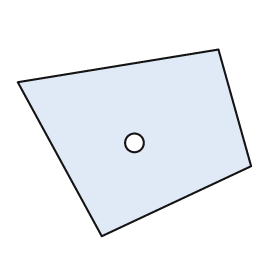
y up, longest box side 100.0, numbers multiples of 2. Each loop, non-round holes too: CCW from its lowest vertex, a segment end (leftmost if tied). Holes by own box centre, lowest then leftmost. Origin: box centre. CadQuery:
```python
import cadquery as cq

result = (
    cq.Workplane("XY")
    .moveTo(-14.0, -40.0)
    .lineTo(50.0, -10.0)
    .lineTo(36.0, 40.0)
    .lineTo(-50.0, 26.0)
    .close()
    .moveTo(0.0, 0.0)
    .circle(4.0)
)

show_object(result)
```